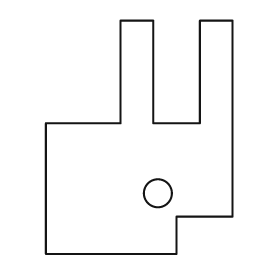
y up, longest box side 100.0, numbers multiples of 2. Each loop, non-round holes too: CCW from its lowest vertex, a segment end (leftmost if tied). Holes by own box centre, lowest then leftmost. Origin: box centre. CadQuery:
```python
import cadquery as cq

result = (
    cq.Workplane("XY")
    .moveTo(-40.0, -50.0)
    .lineTo(16.0, -50.0)
    .lineTo(16.0, -34.0)
    .lineTo(40.0, -34.0)
    .lineTo(40.0, 50.0)
    .lineTo(26.0, 50.0)
    .lineTo(26.0, 6.0)
    .lineTo(6.0, 6.0)
    .lineTo(6.0, 50.0)
    .lineTo(-8.0, 50.0)
    .lineTo(-8.0, 6.0)
    .lineTo(-40.0, 6.0)
    .close()
    .moveTo(8.0, -24.0)
    .circle(6.0)
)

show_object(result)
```